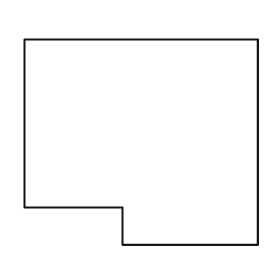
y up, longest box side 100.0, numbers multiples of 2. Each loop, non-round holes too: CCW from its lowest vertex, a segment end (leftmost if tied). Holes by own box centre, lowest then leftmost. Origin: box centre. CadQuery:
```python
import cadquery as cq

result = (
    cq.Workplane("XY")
    .moveTo(-8.0, -44.0)
    .lineTo(50.0, -44.0)
    .lineTo(50.0, 44.0)
    .lineTo(-50.0, 44.0)
    .lineTo(-50.0, -28.0)
    .lineTo(-8.0, -28.0)
    .close()
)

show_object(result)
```